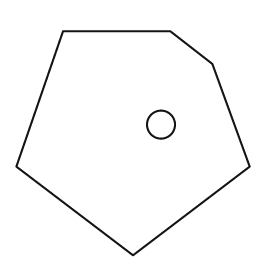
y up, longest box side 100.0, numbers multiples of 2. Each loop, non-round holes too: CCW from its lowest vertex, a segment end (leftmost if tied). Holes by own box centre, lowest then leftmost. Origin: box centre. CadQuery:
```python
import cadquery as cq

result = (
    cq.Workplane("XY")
    .moveTo(0.0, -48.0)
    .lineTo(50.0, -10.0)
    .lineTo(34.0, 34.0)
    .lineTo(16.0, 48.0)
    .lineTo(-30.0, 48.0)
    .lineTo(-50.0, -10.0)
    .close()
    .moveTo(12.0, 8.0)
    .circle(6.0)
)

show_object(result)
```